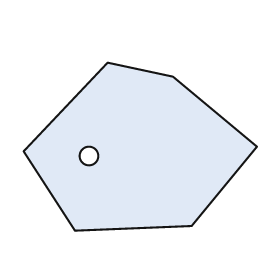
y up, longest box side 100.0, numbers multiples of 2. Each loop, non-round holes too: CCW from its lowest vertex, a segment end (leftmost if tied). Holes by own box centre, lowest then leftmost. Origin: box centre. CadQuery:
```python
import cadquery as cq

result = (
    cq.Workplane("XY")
    .moveTo(-28.0, -36.0)
    .lineTo(22.0, -34.0)
    .lineTo(50.0, 0.0)
    .lineTo(14.0, 30.0)
    .lineTo(-14.0, 36.0)
    .lineTo(-50.0, -2.0)
    .close()
    .moveTo(-22.0, -4.0)
    .circle(4.0)
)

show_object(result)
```